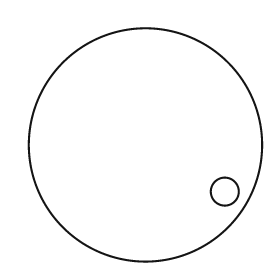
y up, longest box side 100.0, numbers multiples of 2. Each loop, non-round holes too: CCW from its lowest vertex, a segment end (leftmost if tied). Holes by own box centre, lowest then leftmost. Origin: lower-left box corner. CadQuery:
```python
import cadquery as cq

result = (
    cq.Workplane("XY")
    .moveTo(50.0, 50.0)
    .circle(50.0)
    .moveTo(84.0, 30.0)
    .circle(6.0)
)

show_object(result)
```